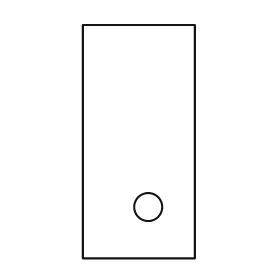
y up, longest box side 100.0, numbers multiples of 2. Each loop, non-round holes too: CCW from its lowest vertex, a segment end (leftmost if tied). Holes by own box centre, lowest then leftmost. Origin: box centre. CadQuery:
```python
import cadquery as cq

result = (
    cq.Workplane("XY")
    .moveTo(-24.0, -50.0)
    .lineTo(24.0, -50.0)
    .lineTo(24.0, 50.0)
    .lineTo(-24.0, 50.0)
    .close()
    .moveTo(4.0, -28.0)
    .circle(6.0)
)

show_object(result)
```